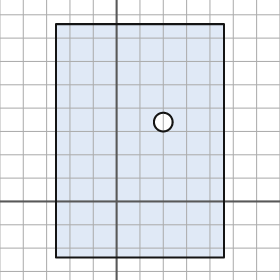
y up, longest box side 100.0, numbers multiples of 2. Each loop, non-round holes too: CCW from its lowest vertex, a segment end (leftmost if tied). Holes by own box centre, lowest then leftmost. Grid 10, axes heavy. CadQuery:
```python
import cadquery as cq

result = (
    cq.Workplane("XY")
    .moveTo(-26.0, -24.0)
    .lineTo(46.0, -24.0)
    .lineTo(46.0, 76.0)
    .lineTo(-26.0, 76.0)
    .close()
    .moveTo(20.0, 34.0)
    .circle(4.0)
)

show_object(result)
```